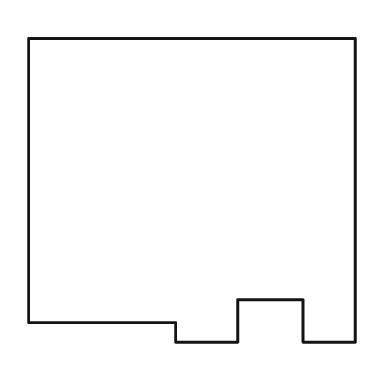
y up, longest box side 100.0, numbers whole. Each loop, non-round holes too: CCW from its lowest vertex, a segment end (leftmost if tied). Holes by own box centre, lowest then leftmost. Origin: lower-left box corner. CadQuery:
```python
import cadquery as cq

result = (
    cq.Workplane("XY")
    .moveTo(45.0, 0.0)
    .lineTo(64.0, 0.0)
    .lineTo(64.0, 13.0)
    .lineTo(84.0, 13.0)
    .lineTo(84.0, 0.0)
    .lineTo(100.0, 0.0)
    .lineTo(100.0, 93.0)
    .lineTo(0.0, 93.0)
    .lineTo(0.0, 6.0)
    .lineTo(45.0, 6.0)
    .close()
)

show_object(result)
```